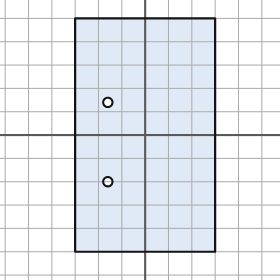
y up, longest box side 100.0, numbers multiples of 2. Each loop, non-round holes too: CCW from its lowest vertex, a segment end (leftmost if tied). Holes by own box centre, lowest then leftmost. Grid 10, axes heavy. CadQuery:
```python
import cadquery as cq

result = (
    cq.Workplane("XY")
    .moveTo(-30.0, -50.0)
    .lineTo(30.0, -50.0)
    .lineTo(30.0, 50.0)
    .lineTo(-30.0, 50.0)
    .close()
    .moveTo(-16.0, -20.0)
    .circle(2.0)
    .moveTo(-16.0, 14.0)
    .circle(2.0)
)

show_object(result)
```